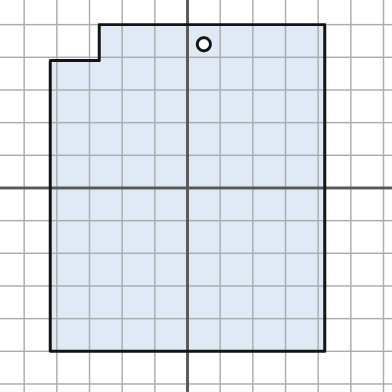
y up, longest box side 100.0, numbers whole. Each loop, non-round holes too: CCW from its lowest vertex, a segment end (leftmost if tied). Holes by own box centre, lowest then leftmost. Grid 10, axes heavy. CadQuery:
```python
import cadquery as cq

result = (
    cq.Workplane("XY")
    .moveTo(-42.0, -50.0)
    .lineTo(42.0, -50.0)
    .lineTo(42.0, 50.0)
    .lineTo(-27.0, 50.0)
    .lineTo(-27.0, 39.0)
    .lineTo(-42.0, 39.0)
    .close()
    .moveTo(5.0, 44.0)
    .circle(2.0)
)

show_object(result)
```